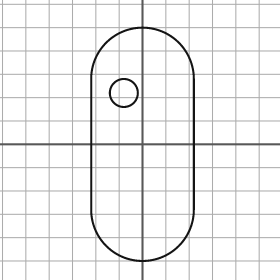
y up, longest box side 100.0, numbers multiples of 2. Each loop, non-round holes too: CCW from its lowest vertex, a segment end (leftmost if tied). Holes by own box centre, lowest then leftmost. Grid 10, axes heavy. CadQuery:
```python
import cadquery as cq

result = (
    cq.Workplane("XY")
    .moveTo(-22.0, -28.0)
    .threePointArc((0.0, -50.0), (22.0, -28.0))
    .lineTo(22.0, 28.0)
    .threePointArc((0.0, 50.0), (-22.0, 28.0))
    .close()
    .moveTo(-8.0, 22.0)
    .circle(6.0)
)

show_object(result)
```